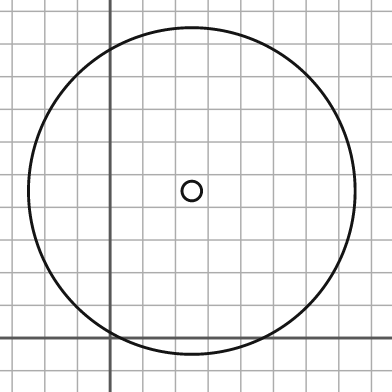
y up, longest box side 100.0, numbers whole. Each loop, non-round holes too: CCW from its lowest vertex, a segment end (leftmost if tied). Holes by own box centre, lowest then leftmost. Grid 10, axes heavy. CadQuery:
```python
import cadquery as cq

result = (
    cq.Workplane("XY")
    .moveTo(25.0, 45.0)
    .circle(50.0)
    .moveTo(25.0, 45.0)
    .circle(3.0)
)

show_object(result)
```